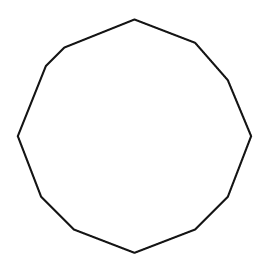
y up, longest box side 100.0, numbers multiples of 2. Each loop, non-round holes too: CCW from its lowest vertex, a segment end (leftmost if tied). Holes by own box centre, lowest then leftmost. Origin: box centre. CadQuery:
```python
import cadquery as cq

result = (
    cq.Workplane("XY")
    .moveTo(0.0, -50.0)
    .lineTo(26.0, -40.0)
    .lineTo(40.0, -26.0)
    .lineTo(50.0, 0.0)
    .lineTo(40.0, 24.0)
    .lineTo(26.0, 40.0)
    .lineTo(0.0, 50.0)
    .lineTo(-30.0, 38.0)
    .lineTo(-38.0, 30.0)
    .lineTo(-50.0, 0.0)
    .lineTo(-40.0, -26.0)
    .lineTo(-26.0, -40.0)
    .close()
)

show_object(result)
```